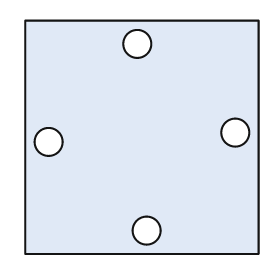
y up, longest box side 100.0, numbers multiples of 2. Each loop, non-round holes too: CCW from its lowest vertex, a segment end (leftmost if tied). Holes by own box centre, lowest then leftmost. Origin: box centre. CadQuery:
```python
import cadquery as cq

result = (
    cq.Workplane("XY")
    .moveTo(-50.0, -50.0)
    .lineTo(50.0, -50.0)
    .lineTo(50.0, 50.0)
    .lineTo(-50.0, 50.0)
    .close()
    .moveTo(2.0, -40.0)
    .circle(6.0)
    .moveTo(-40.0, -2.0)
    .circle(6.0)
    .moveTo(40.0, 2.0)
    .circle(6.0)
    .moveTo(-2.0, 40.0)
    .circle(6.0)
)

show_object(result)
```